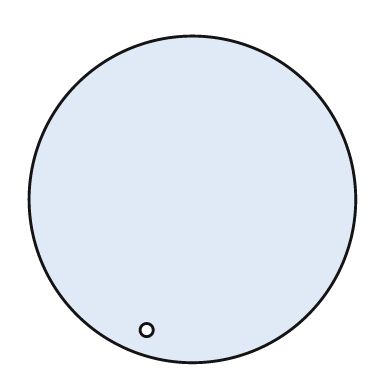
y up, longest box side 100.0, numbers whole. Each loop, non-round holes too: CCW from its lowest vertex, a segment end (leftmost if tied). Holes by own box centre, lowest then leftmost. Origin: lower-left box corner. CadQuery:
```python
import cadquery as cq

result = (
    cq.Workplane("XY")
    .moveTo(50.0, 50.0)
    .circle(50.0)
    .moveTo(36.0, 10.0)
    .circle(2.0)
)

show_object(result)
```